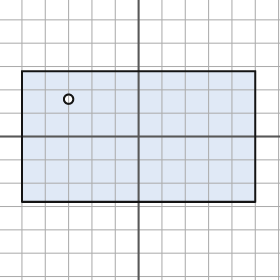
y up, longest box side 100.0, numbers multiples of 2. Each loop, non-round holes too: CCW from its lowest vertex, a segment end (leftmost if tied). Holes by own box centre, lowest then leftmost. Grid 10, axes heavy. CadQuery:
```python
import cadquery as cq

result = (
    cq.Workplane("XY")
    .moveTo(-50.0, -28.0)
    .lineTo(50.0, -28.0)
    .lineTo(50.0, 28.0)
    .lineTo(-50.0, 28.0)
    .close()
    .moveTo(-30.0, 16.0)
    .circle(2.0)
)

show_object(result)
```